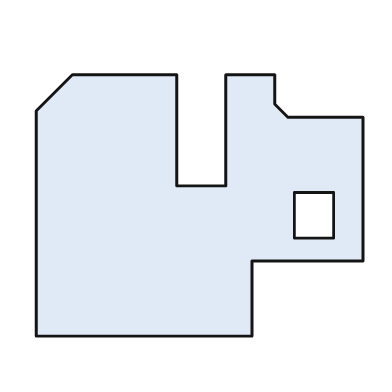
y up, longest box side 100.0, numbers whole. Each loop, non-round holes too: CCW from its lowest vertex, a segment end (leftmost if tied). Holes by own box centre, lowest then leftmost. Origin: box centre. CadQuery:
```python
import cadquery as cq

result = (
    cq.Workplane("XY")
    .moveTo(-50.0, -40.0)
    .lineTo(16.0, -40.0)
    .lineTo(16.0, -17.0)
    .lineTo(50.0, -17.0)
    .lineTo(50.0, 27.0)
    .lineTo(27.0, 27.0)
    .lineTo(23.0, 31.0)
    .lineTo(23.0, 40.0)
    .lineTo(8.0, 40.0)
    .lineTo(8.0, 6.0)
    .lineTo(-7.0, 6.0)
    .lineTo(-7.0, 40.0)
    .lineTo(-39.0, 40.0)
    .lineTo(-50.0, 29.0)
    .close()
    .moveTo(29.0, -10.0)
    .lineTo(41.0, -10.0)
    .lineTo(41.0, 4.0)
    .lineTo(29.0, 4.0)
    .close()
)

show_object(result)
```